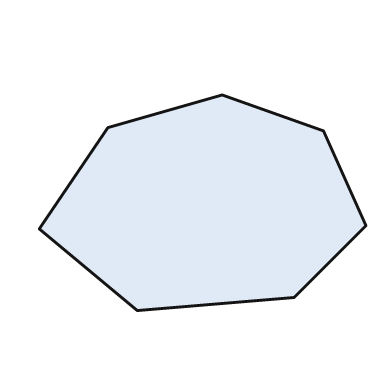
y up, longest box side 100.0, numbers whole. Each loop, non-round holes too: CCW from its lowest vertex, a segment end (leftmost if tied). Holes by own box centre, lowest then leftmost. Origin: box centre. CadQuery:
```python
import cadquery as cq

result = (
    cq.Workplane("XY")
    .moveTo(-20.0, -33.0)
    .lineTo(28.0, -29.0)
    .lineTo(50.0, -7.0)
    .lineTo(37.0, 22.0)
    .lineTo(6.0, 33.0)
    .lineTo(-29.0, 23.0)
    .lineTo(-50.0, -8.0)
    .close()
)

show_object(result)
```